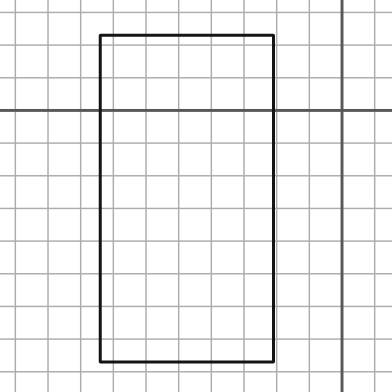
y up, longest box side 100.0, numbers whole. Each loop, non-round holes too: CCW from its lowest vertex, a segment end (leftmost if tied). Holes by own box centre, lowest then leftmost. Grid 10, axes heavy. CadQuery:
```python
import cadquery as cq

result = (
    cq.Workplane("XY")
    .moveTo(-74.0, -77.0)
    .lineTo(-21.0, -77.0)
    .lineTo(-21.0, 23.0)
    .lineTo(-74.0, 23.0)
    .close()
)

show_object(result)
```